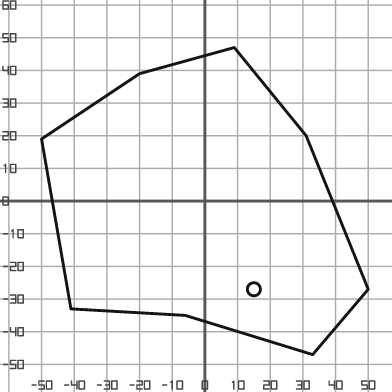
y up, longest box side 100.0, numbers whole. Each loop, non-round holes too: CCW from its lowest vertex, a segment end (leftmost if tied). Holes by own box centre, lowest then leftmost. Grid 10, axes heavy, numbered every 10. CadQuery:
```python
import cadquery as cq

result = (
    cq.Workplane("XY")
    .moveTo(33.0, -47.0)
    .lineTo(50.0, -27.0)
    .lineTo(31.0, 20.0)
    .lineTo(9.0, 47.0)
    .lineTo(-20.0, 39.0)
    .lineTo(-50.0, 19.0)
    .lineTo(-41.0, -33.0)
    .lineTo(-6.0, -35.0)
    .close()
    .moveTo(15.0, -27.0)
    .circle(2.0)
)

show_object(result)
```